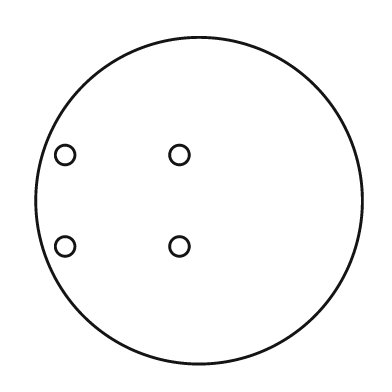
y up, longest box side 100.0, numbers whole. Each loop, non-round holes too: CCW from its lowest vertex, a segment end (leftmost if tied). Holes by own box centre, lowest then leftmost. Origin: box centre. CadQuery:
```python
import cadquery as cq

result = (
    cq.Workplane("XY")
    .moveTo(0.0, 0.0)
    .circle(50.0)
    .moveTo(-41.0, -14.0)
    .circle(3.0)
    .moveTo(-6.0, -14.0)
    .circle(3.0)
    .moveTo(-41.0, 14.0)
    .circle(3.0)
    .moveTo(-6.0, 14.0)
    .circle(3.0)
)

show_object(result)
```